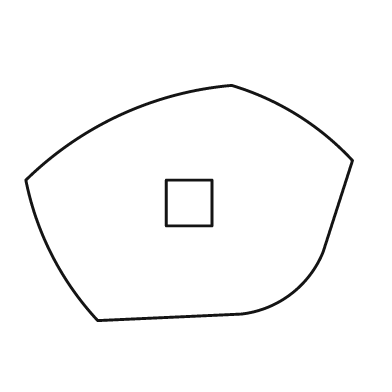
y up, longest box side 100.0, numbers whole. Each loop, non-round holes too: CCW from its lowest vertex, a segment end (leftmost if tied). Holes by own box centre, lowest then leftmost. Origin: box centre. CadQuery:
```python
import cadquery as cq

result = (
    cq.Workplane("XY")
    .moveTo(-28.0, -36.0)
    .lineTo(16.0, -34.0)
    .threePointArc((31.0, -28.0), (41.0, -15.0))
    .lineTo(50.0, 13.0)
    .threePointArc((33.0, 27.0), (13.0, 36.0))
    .threePointArc((-21.0, 27.0), (-50.0, 7.0))
    .threePointArc((-42.0, -16.0), (-28.0, -36.0))
    .close()
    .moveTo(-7.0, -7.0)
    .lineTo(7.0, -7.0)
    .lineTo(7.0, 7.0)
    .lineTo(-7.0, 7.0)
    .close()
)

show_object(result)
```